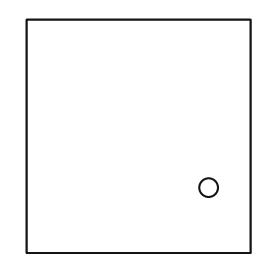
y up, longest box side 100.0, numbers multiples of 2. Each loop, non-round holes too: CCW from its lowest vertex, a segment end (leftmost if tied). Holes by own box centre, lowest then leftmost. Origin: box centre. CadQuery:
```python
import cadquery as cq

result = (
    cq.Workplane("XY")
    .moveTo(-48.0, -50.0)
    .lineTo(48.0, -50.0)
    .lineTo(48.0, 50.0)
    .lineTo(-48.0, 50.0)
    .close()
    .moveTo(30.0, -22.0)
    .circle(4.0)
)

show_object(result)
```